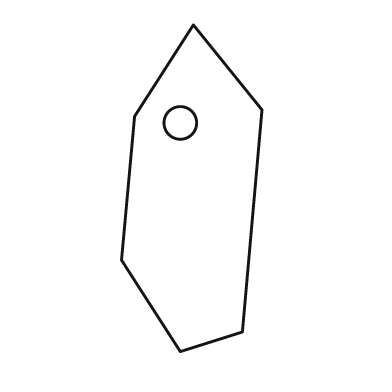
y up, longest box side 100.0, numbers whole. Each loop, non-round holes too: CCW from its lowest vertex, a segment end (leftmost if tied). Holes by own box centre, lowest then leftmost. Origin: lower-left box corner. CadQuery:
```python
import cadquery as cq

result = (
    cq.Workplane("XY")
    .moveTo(18.0, 0.0)
    .lineTo(37.0, 6.0)
    .lineTo(43.0, 74.0)
    .lineTo(22.0, 100.0)
    .lineTo(4.0, 72.0)
    .lineTo(0.0, 28.0)
    .close()
    .moveTo(18.0, 70.0)
    .circle(5.0)
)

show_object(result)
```